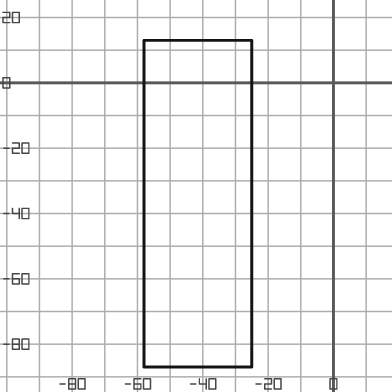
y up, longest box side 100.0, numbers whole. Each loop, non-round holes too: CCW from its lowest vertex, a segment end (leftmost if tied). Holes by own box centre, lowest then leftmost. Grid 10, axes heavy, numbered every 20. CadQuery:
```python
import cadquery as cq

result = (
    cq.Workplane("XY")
    .moveTo(-58.0, -87.0)
    .lineTo(-25.0, -87.0)
    .lineTo(-25.0, 13.0)
    .lineTo(-58.0, 13.0)
    .close()
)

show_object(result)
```